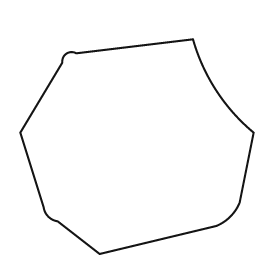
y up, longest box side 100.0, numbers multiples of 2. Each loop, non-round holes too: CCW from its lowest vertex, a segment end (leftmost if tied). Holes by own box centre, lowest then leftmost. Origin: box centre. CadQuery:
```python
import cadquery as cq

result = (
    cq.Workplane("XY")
    .moveTo(-16.0, -46.0)
    .lineTo(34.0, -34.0)
    .threePointArc((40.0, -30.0), (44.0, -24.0))
    .lineTo(50.0, 6.0)
    .threePointArc((34.0, 24.0), (24.0, 46.0))
    .lineTo(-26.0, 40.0)
    .threePointArc((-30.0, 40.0), (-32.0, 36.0))
    .lineTo(-50.0, 6.0)
    .lineTo(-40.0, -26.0)
    .threePointArc((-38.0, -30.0), (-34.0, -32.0))
    .close()
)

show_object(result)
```